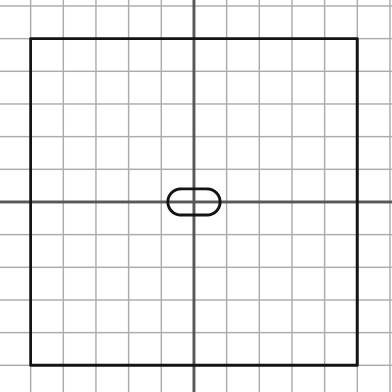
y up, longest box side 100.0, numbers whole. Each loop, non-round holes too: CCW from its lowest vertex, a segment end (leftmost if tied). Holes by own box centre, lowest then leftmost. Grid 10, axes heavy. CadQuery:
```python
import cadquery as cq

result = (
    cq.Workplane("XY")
    .moveTo(-50.0, -50.0)
    .lineTo(50.0, -50.0)
    .lineTo(50.0, 50.0)
    .lineTo(-50.0, 50.0)
    .close()
    .moveTo(-4.0, -4.0)
    .lineTo(4.0, -4.0)
    .threePointArc((8.0, 0.0), (4.0, 4.0))
    .lineTo(-4.0, 4.0)
    .threePointArc((-8.0, 0.0), (-4.0, -4.0))
    .close()
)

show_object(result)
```